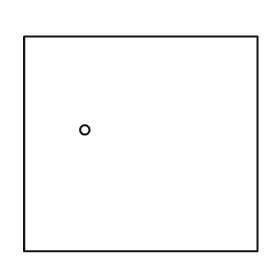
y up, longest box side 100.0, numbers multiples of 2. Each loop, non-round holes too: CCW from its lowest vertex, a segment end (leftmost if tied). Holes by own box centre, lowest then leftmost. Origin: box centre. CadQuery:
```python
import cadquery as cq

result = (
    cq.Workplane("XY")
    .moveTo(-50.0, -46.0)
    .lineTo(50.0, -46.0)
    .lineTo(50.0, 46.0)
    .lineTo(-50.0, 46.0)
    .close()
    .moveTo(-24.0, 6.0)
    .circle(2.0)
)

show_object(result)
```